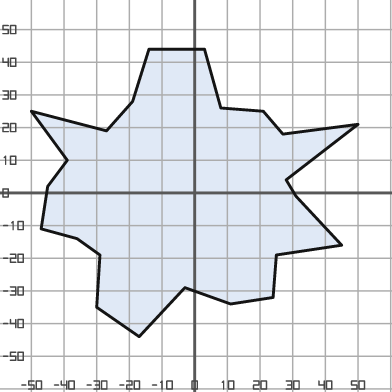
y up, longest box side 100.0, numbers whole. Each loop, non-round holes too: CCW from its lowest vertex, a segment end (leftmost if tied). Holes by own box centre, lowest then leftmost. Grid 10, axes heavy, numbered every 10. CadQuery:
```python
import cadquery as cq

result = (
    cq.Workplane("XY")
    .moveTo(-17.0, -44.0)
    .lineTo(-3.0, -29.0)
    .lineTo(11.0, -34.0)
    .lineTo(24.0, -32.0)
    .lineTo(25.0, -19.0)
    .lineTo(45.0, -16.0)
    .lineTo(31.0, -1.0)
    .lineTo(28.0, 4.0)
    .lineTo(50.0, 21.0)
    .lineTo(27.0, 18.0)
    .lineTo(21.0, 25.0)
    .lineTo(8.0, 26.0)
    .lineTo(3.0, 44.0)
    .lineTo(-14.0, 44.0)
    .lineTo(-19.0, 28.0)
    .lineTo(-27.0, 19.0)
    .lineTo(-50.0, 25.0)
    .lineTo(-39.0, 10.0)
    .lineTo(-45.0, 2.0)
    .lineTo(-47.0, -11.0)
    .lineTo(-36.0, -14.0)
    .lineTo(-29.0, -19.0)
    .lineTo(-30.0, -35.0)
    .close()
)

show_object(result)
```